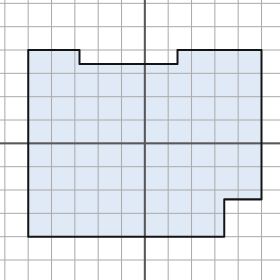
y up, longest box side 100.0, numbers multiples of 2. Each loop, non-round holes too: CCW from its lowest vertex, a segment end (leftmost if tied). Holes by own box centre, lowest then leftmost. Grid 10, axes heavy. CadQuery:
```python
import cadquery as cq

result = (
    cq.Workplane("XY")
    .moveTo(-50.0, -40.0)
    .lineTo(34.0, -40.0)
    .lineTo(34.0, -24.0)
    .lineTo(50.0, -24.0)
    .lineTo(50.0, 40.0)
    .lineTo(14.0, 40.0)
    .lineTo(14.0, 34.0)
    .lineTo(-28.0, 34.0)
    .lineTo(-28.0, 40.0)
    .lineTo(-50.0, 40.0)
    .close()
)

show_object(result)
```